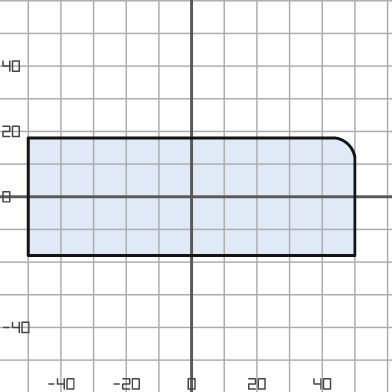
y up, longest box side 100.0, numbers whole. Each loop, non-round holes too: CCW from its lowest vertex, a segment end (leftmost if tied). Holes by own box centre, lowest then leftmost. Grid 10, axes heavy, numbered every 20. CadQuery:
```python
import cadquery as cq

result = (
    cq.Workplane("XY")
    .moveTo(-50.0, -18.0)
    .lineTo(50.0, -18.0)
    .lineTo(50.0, 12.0)
    .threePointArc((48.0, 16.0), (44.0, 18.0))
    .lineTo(-50.0, 18.0)
    .close()
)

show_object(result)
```